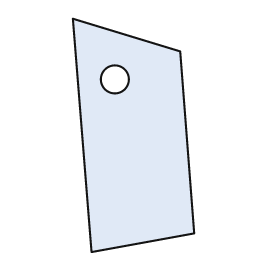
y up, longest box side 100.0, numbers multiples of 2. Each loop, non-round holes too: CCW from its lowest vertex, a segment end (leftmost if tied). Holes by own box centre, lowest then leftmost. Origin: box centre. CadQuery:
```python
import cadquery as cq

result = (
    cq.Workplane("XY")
    .moveTo(-18.0, -50.0)
    .lineTo(26.0, -42.0)
    .lineTo(20.0, 36.0)
    .lineTo(-26.0, 50.0)
    .close()
    .moveTo(-8.0, 24.0)
    .circle(6.0)
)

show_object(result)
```